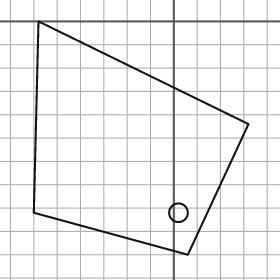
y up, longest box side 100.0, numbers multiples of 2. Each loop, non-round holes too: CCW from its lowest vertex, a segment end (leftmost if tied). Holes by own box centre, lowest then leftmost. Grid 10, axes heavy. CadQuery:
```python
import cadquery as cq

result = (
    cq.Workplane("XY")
    .moveTo(6.0, -100.0)
    .lineTo(32.0, -44.0)
    .lineTo(-58.0, 0.0)
    .lineTo(-60.0, -82.0)
    .close()
    .moveTo(2.0, -82.0)
    .circle(4.0)
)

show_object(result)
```